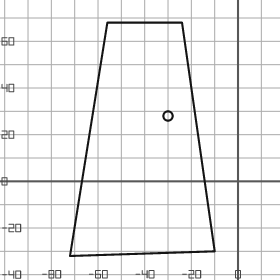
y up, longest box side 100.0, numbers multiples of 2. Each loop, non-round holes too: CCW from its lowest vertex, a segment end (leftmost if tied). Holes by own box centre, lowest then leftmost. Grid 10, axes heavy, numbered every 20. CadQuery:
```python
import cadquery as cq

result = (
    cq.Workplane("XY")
    .moveTo(-72.0, -32.0)
    .lineTo(-10.0, -30.0)
    .lineTo(-24.0, 68.0)
    .lineTo(-56.0, 68.0)
    .close()
    .moveTo(-30.0, 28.0)
    .circle(2.0)
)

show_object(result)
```